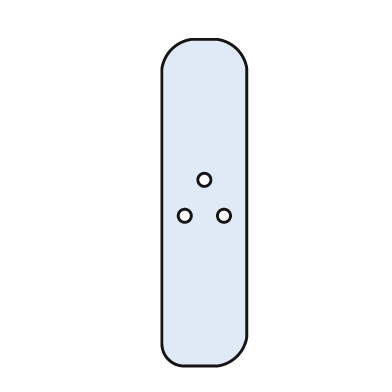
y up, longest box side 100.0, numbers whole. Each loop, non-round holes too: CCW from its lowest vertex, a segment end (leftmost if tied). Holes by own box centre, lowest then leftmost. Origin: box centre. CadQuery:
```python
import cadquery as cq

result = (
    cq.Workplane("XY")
    .moveTo(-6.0, -50.0)
    .lineTo(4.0, -50.0)
    .threePointArc((10.0, -47.0), (13.0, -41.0))
    .lineTo(13.0, 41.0)
    .threePointArc((10.0, 47.0), (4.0, 50.0))
    .lineTo(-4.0, 50.0)
    .threePointArc((-10.0, 47.0), (-13.0, 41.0))
    .lineTo(-13.0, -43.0)
    .threePointArc((-11.0, -48.0), (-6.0, -50.0))
    .close()
    .moveTo(-6.0, -4.0)
    .circle(2.0)
    .moveTo(6.0, -4.0)
    .circle(2.0)
    .moveTo(0.0, 7.0)
    .circle(2.0)
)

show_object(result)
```